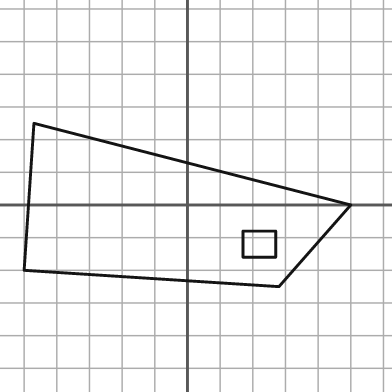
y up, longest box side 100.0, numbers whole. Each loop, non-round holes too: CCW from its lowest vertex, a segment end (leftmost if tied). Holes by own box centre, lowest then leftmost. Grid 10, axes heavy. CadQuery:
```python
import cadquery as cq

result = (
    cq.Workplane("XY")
    .moveTo(28.0, -25.0)
    .lineTo(50.0, 0.0)
    .lineTo(-47.0, 25.0)
    .lineTo(-50.0, -20.0)
    .close()
    .moveTo(17.0, -16.0)
    .lineTo(27.0, -16.0)
    .lineTo(27.0, -8.0)
    .lineTo(17.0, -8.0)
    .close()
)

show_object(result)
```